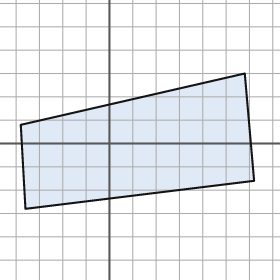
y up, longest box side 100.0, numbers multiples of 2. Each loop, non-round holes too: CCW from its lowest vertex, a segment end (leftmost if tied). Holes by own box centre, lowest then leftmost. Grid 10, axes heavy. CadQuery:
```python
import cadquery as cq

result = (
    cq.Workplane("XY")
    .moveTo(-36.0, -28.0)
    .lineTo(62.0, -16.0)
    .lineTo(58.0, 30.0)
    .lineTo(-38.0, 8.0)
    .close()
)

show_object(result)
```